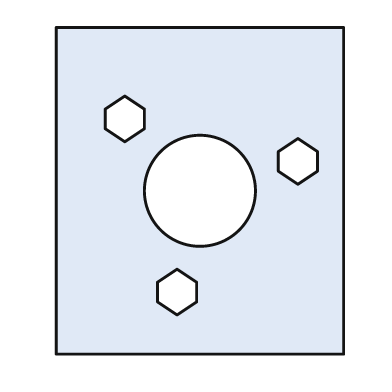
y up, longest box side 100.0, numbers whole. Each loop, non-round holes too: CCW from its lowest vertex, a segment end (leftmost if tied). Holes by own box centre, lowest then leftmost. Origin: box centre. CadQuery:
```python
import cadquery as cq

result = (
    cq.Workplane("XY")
    .moveTo(-44.0, -50.0)
    .lineTo(44.0, -50.0)
    .lineTo(44.0, 50.0)
    .lineTo(-44.0, 50.0)
    .close()
    .moveTo(-7.0, -38.0)
    .lineTo(-1.0, -34.0)
    .lineTo(-1.0, -28.0)
    .lineTo(-7.0, -24.0)
    .lineTo(-13.0, -28.0)
    .lineTo(-13.0, -34.0)
    .close()
    .moveTo(0.0, 0.0)
    .circle(17.0)
    .moveTo(30.0, 2.0)
    .lineTo(36.0, 6.0)
    .lineTo(36.0, 12.0)
    .lineTo(30.0, 16.0)
    .lineTo(24.0, 12.0)
    .lineTo(24.0, 6.0)
    .close()
    .moveTo(-23.0, 15.0)
    .lineTo(-17.0, 19.0)
    .lineTo(-17.0, 25.0)
    .lineTo(-23.0, 29.0)
    .lineTo(-29.0, 25.0)
    .lineTo(-29.0, 19.0)
    .close()
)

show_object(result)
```